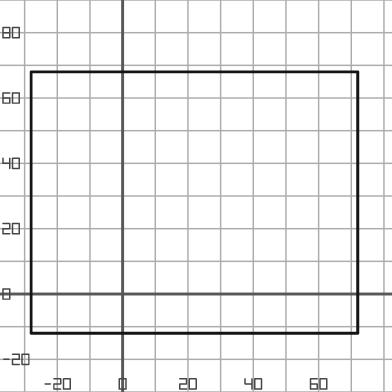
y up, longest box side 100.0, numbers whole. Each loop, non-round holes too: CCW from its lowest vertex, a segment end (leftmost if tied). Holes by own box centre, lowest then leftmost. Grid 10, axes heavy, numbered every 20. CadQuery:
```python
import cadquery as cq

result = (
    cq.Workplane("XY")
    .moveTo(-28.0, -12.0)
    .lineTo(72.0, -12.0)
    .lineTo(72.0, 68.0)
    .lineTo(-28.0, 68.0)
    .close()
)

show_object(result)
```